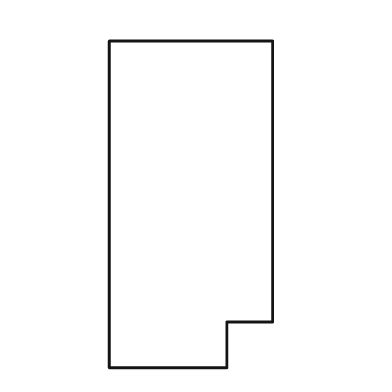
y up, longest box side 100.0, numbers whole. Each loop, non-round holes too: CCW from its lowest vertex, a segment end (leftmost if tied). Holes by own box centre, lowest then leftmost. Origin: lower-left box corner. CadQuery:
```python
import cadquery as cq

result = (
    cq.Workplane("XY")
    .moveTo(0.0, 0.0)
    .lineTo(36.0, 0.0)
    .lineTo(36.0, 14.0)
    .lineTo(50.0, 14.0)
    .lineTo(50.0, 100.0)
    .lineTo(0.0, 100.0)
    .close()
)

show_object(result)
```